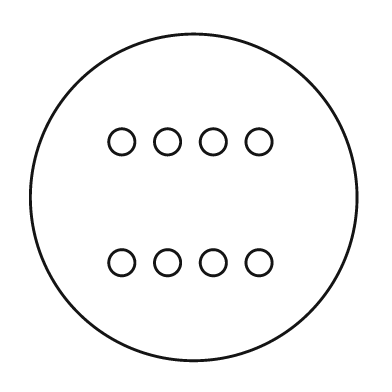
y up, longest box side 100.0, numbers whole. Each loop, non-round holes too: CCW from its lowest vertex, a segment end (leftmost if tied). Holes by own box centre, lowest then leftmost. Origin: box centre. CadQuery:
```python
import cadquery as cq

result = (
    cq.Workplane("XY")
    .moveTo(0.0, 0.0)
    .circle(50.0)
    .moveTo(-22.0, -20.0)
    .circle(4.0)
    .moveTo(-8.0, -20.0)
    .circle(4.0)
    .moveTo(6.0, -20.0)
    .circle(4.0)
    .moveTo(20.0, -20.0)
    .circle(4.0)
    .moveTo(-22.0, 17.0)
    .circle(4.0)
    .moveTo(-8.0, 17.0)
    .circle(4.0)
    .moveTo(6.0, 17.0)
    .circle(4.0)
    .moveTo(20.0, 17.0)
    .circle(4.0)
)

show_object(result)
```